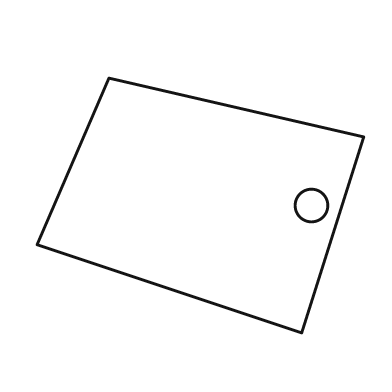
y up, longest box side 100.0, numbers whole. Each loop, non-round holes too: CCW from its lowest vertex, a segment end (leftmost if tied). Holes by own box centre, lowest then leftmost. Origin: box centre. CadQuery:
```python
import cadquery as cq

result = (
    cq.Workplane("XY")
    .moveTo(31.0, -39.0)
    .lineTo(50.0, 21.0)
    .lineTo(-28.0, 39.0)
    .lineTo(-50.0, -12.0)
    .close()
    .moveTo(34.0, 0.0)
    .circle(5.0)
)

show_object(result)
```